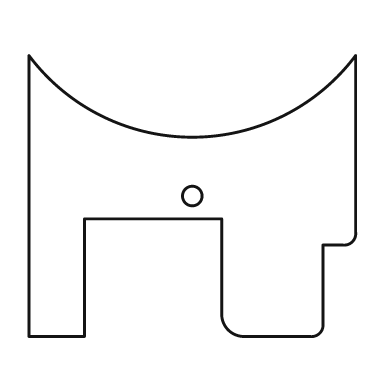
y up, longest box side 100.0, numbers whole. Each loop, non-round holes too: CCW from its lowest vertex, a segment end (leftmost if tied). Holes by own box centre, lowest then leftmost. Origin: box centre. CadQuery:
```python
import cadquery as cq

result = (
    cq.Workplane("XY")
    .moveTo(-50.0, -43.0)
    .lineTo(-33.0, -43.0)
    .lineTo(-33.0, -7.0)
    .lineTo(9.0, -7.0)
    .lineTo(9.0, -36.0)
    .threePointArc((11.0, -41.0), (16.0, -43.0))
    .lineTo(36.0, -43.0)
    .threePointArc((39.0, -42.0), (40.0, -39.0))
    .lineTo(40.0, -15.0)
    .lineTo(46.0, -15.0)
    .threePointArc((49.0, -14.0), (50.0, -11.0))
    .lineTo(50.0, 43.0)
    .threePointArc((0.0, 18.0), (-50.0, 43.0))
    .close()
    .moveTo(0.0, 0.0)
    .circle(3.0)
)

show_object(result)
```